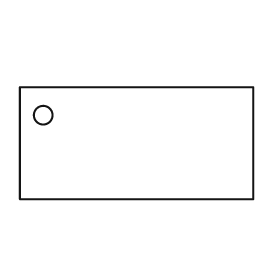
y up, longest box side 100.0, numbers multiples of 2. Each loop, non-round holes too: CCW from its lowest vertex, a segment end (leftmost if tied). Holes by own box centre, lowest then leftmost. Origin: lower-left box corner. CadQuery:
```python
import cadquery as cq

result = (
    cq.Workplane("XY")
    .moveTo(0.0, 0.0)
    .lineTo(100.0, 0.0)
    .lineTo(100.0, 48.0)
    .lineTo(0.0, 48.0)
    .close()
    .moveTo(10.0, 36.0)
    .circle(4.0)
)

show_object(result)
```